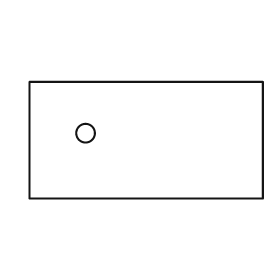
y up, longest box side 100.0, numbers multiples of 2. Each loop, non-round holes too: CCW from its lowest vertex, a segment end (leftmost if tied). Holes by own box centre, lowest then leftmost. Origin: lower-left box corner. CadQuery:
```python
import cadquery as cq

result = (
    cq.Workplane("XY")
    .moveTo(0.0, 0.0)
    .lineTo(100.0, 0.0)
    .lineTo(100.0, 50.0)
    .lineTo(0.0, 50.0)
    .close()
    .moveTo(24.0, 28.0)
    .circle(4.0)
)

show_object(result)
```